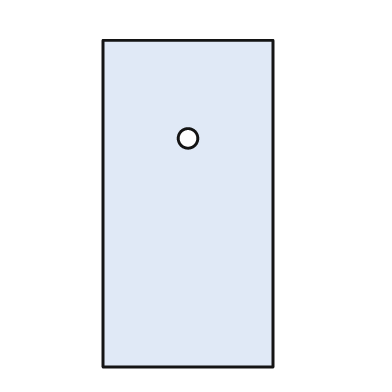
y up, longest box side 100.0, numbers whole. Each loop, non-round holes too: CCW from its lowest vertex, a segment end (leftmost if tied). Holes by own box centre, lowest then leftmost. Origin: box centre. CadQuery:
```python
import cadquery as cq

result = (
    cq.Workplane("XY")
    .moveTo(-26.0, -50.0)
    .lineTo(26.0, -50.0)
    .lineTo(26.0, 50.0)
    .lineTo(-26.0, 50.0)
    .close()
    .moveTo(0.0, 20.0)
    .circle(3.0)
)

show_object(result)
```